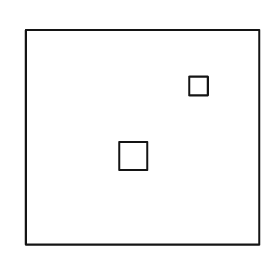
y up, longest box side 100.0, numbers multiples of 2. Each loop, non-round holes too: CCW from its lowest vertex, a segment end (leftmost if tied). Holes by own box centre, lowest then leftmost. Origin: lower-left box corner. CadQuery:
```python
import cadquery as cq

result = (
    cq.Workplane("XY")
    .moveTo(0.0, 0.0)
    .lineTo(100.0, 0.0)
    .lineTo(100.0, 92.0)
    .lineTo(0.0, 92.0)
    .close()
    .moveTo(40.0, 32.0)
    .lineTo(52.0, 32.0)
    .lineTo(52.0, 44.0)
    .lineTo(40.0, 44.0)
    .close()
    .moveTo(70.0, 64.0)
    .lineTo(78.0, 64.0)
    .lineTo(78.0, 72.0)
    .lineTo(70.0, 72.0)
    .close()
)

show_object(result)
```